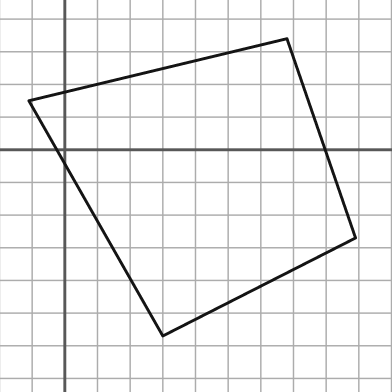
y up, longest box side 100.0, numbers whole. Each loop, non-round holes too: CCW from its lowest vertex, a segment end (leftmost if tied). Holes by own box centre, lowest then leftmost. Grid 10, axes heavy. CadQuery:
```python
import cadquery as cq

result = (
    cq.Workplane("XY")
    .moveTo(30.0, -57.0)
    .lineTo(89.0, -27.0)
    .lineTo(68.0, 34.0)
    .lineTo(-11.0, 15.0)
    .close()
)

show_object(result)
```